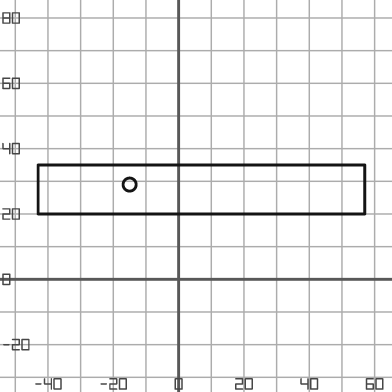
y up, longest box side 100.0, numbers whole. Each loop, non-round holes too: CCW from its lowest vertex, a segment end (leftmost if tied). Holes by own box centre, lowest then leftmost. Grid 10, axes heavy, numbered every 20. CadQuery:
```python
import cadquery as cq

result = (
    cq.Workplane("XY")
    .moveTo(-43.0, 20.0)
    .lineTo(57.0, 20.0)
    .lineTo(57.0, 35.0)
    .lineTo(-43.0, 35.0)
    .close()
    .moveTo(-15.0, 29.0)
    .circle(2.0)
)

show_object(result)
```